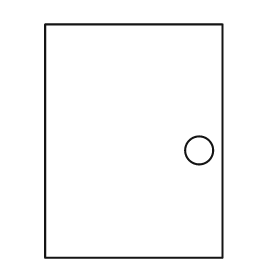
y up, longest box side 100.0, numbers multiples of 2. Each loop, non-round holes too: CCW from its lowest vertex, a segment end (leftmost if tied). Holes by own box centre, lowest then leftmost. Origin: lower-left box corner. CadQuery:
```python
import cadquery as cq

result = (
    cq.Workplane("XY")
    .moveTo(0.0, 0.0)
    .lineTo(76.0, 0.0)
    .lineTo(76.0, 100.0)
    .lineTo(0.0, 100.0)
    .close()
    .moveTo(66.0, 46.0)
    .circle(6.0)
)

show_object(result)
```